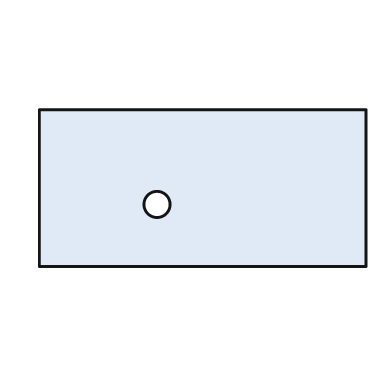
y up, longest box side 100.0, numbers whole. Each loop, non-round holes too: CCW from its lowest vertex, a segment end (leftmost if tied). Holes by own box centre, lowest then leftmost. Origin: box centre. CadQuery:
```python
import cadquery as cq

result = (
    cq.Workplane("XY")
    .moveTo(-50.0, -24.0)
    .lineTo(50.0, -24.0)
    .lineTo(50.0, 24.0)
    .lineTo(-50.0, 24.0)
    .close()
    .moveTo(-14.0, -5.0)
    .circle(4.0)
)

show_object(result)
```